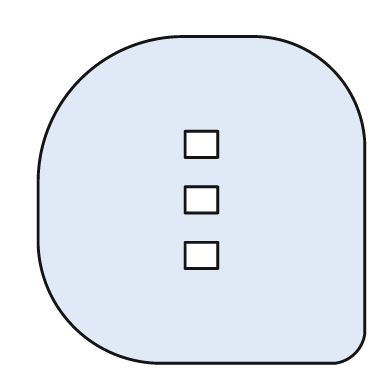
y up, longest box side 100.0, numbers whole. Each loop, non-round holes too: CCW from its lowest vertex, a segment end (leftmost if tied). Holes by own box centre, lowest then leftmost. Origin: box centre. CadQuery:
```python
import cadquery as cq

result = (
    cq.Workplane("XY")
    .moveTo(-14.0, -50.0)
    .lineTo(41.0, -50.0)
    .threePointArc((47.0, -47.0), (50.0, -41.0))
    .lineTo(50.0, 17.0)
    .threePointArc((40.0, 40.0), (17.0, 50.0))
    .lineTo(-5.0, 50.0)
    .threePointArc((-37.0, 37.0), (-50.0, 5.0))
    .lineTo(-50.0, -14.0)
    .threePointArc((-39.0, -39.0), (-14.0, -50.0))
    .close()
    .moveTo(-5.0, -21.0)
    .lineTo(5.0, -21.0)
    .lineTo(5.0, -13.0)
    .lineTo(-5.0, -13.0)
    .close()
    .moveTo(-5.0, -4.0)
    .lineTo(5.0, -4.0)
    .lineTo(5.0, 4.0)
    .lineTo(-5.0, 4.0)
    .close()
    .moveTo(-5.0, 13.0)
    .lineTo(5.0, 13.0)
    .lineTo(5.0, 21.0)
    .lineTo(-5.0, 21.0)
    .close()
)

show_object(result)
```